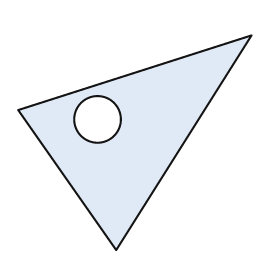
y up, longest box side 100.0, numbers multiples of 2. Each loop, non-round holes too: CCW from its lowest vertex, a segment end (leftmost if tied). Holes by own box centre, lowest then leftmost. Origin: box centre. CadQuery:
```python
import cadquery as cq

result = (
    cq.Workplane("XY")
    .moveTo(-8.0, -46.0)
    .lineTo(50.0, 46.0)
    .lineTo(-50.0, 14.0)
    .close()
    .moveTo(-16.0, 10.0)
    .circle(10.0)
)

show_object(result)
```